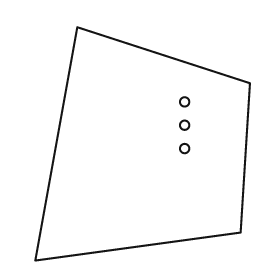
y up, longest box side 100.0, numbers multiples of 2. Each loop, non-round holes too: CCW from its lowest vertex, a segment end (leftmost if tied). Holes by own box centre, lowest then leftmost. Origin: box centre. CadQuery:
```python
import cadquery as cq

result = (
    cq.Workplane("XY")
    .moveTo(-46.0, -50.0)
    .lineTo(42.0, -38.0)
    .lineTo(46.0, 26.0)
    .lineTo(-28.0, 50.0)
    .close()
    .moveTo(18.0, -2.0)
    .circle(2.0)
    .moveTo(18.0, 8.0)
    .circle(2.0)
    .moveTo(18.0, 18.0)
    .circle(2.0)
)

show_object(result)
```